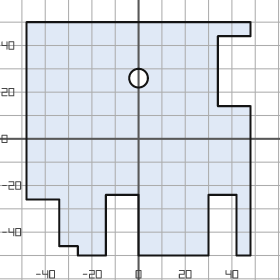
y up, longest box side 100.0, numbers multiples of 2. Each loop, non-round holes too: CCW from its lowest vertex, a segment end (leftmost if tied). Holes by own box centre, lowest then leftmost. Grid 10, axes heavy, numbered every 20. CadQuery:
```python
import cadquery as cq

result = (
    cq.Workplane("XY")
    .moveTo(-26.0, -50.0)
    .lineTo(-14.0, -50.0)
    .lineTo(-14.0, -24.0)
    .lineTo(0.0, -24.0)
    .lineTo(0.0, -50.0)
    .lineTo(30.0, -50.0)
    .lineTo(30.0, -24.0)
    .lineTo(42.0, -24.0)
    .lineTo(42.0, -50.0)
    .lineTo(48.0, -50.0)
    .lineTo(48.0, 14.0)
    .lineTo(34.0, 14.0)
    .lineTo(34.0, 44.0)
    .lineTo(48.0, 44.0)
    .lineTo(48.0, 50.0)
    .lineTo(-48.0, 50.0)
    .lineTo(-48.0, -26.0)
    .lineTo(-34.0, -26.0)
    .lineTo(-34.0, -46.0)
    .lineTo(-26.0, -46.0)
    .close()
    .moveTo(0.0, 26.0)
    .circle(4.0)
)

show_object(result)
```